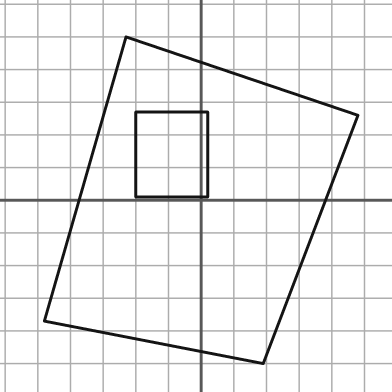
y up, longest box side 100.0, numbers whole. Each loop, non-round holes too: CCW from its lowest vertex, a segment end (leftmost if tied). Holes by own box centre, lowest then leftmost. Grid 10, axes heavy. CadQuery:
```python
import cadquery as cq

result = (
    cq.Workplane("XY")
    .moveTo(19.0, -50.0)
    .lineTo(48.0, 26.0)
    .lineTo(-23.0, 50.0)
    .lineTo(-48.0, -37.0)
    .close()
    .moveTo(-20.0, 1.0)
    .lineTo(2.0, 1.0)
    .lineTo(2.0, 27.0)
    .lineTo(-20.0, 27.0)
    .close()
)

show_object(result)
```